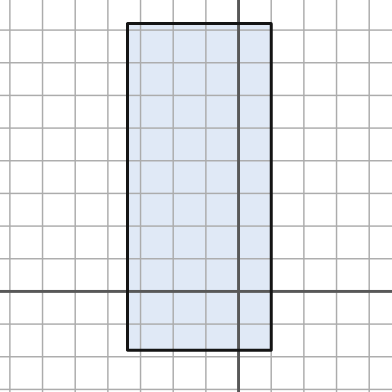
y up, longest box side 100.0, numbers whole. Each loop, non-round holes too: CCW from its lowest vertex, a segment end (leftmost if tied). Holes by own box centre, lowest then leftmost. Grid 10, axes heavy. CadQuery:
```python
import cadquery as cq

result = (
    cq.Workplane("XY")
    .moveTo(-34.0, -18.0)
    .lineTo(10.0, -18.0)
    .lineTo(10.0, 82.0)
    .lineTo(-34.0, 82.0)
    .close()
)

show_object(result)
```